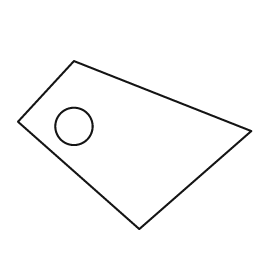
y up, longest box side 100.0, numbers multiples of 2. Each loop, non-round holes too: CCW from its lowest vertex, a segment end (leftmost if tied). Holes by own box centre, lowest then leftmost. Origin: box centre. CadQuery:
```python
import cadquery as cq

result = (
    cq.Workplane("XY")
    .moveTo(2.0, -36.0)
    .lineTo(50.0, 6.0)
    .lineTo(-26.0, 36.0)
    .lineTo(-50.0, 10.0)
    .close()
    .moveTo(-26.0, 8.0)
    .circle(8.0)
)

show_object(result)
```